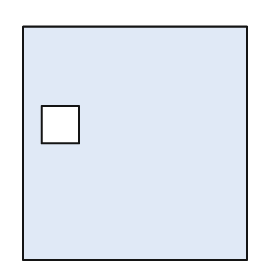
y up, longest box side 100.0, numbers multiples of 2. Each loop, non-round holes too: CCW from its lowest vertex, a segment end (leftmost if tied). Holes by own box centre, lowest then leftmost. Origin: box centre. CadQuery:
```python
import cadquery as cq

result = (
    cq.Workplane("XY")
    .moveTo(-48.0, -50.0)
    .lineTo(48.0, -50.0)
    .lineTo(48.0, 50.0)
    .lineTo(-48.0, 50.0)
    .close()
    .moveTo(-40.0, 0.0)
    .lineTo(-24.0, 0.0)
    .lineTo(-24.0, 16.0)
    .lineTo(-40.0, 16.0)
    .close()
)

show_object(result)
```